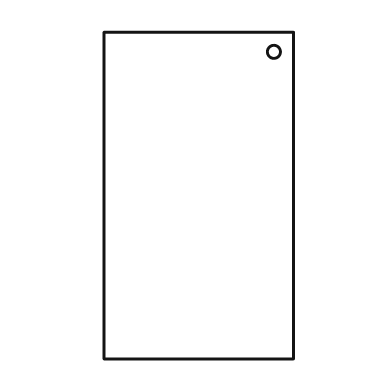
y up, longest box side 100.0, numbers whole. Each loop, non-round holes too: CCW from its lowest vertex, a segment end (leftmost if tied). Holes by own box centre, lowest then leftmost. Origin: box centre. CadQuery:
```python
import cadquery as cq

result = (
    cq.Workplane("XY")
    .moveTo(-29.0, -50.0)
    .lineTo(29.0, -50.0)
    .lineTo(29.0, 50.0)
    .lineTo(-29.0, 50.0)
    .close()
    .moveTo(23.0, 44.0)
    .circle(2.0)
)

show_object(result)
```